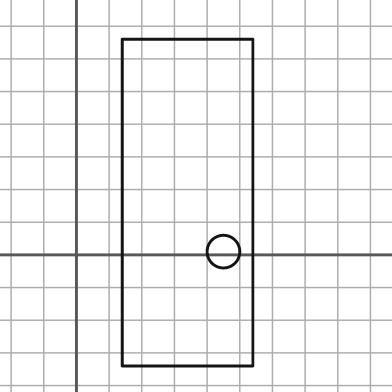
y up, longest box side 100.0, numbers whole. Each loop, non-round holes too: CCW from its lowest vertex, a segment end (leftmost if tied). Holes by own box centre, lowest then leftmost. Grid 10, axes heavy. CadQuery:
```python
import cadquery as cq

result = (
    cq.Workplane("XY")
    .moveTo(14.0, -34.0)
    .lineTo(54.0, -34.0)
    .lineTo(54.0, 66.0)
    .lineTo(14.0, 66.0)
    .close()
    .moveTo(45.0, 1.0)
    .circle(5.0)
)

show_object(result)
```